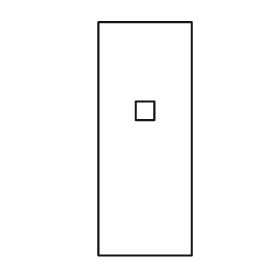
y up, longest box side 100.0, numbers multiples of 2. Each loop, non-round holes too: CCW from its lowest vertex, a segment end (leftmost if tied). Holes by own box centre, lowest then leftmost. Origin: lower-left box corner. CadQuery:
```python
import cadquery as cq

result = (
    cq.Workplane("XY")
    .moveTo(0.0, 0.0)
    .lineTo(40.0, 0.0)
    .lineTo(40.0, 100.0)
    .lineTo(0.0, 100.0)
    .close()
    .moveTo(16.0, 58.0)
    .lineTo(24.0, 58.0)
    .lineTo(24.0, 66.0)
    .lineTo(16.0, 66.0)
    .close()
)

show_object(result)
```